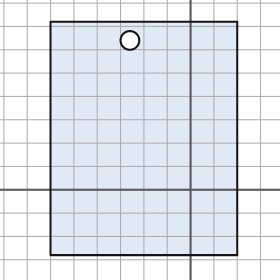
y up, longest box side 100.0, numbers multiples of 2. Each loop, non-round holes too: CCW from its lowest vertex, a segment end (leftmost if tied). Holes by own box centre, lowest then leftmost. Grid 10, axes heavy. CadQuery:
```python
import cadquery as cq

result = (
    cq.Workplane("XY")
    .moveTo(-60.0, -28.0)
    .lineTo(20.0, -28.0)
    .lineTo(20.0, 72.0)
    .lineTo(-60.0, 72.0)
    .close()
    .moveTo(-26.0, 64.0)
    .circle(4.0)
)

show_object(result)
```